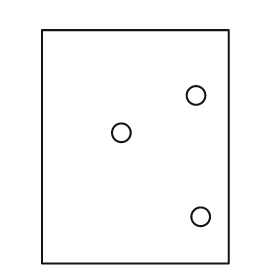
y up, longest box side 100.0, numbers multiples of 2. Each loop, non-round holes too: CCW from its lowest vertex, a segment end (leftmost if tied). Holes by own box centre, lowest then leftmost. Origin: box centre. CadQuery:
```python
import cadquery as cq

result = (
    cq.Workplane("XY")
    .moveTo(-40.0, -50.0)
    .lineTo(40.0, -50.0)
    .lineTo(40.0, 50.0)
    .lineTo(-40.0, 50.0)
    .close()
    .moveTo(28.0, -30.0)
    .circle(4.0)
    .moveTo(-6.0, 6.0)
    .circle(4.0)
    .moveTo(26.0, 22.0)
    .circle(4.0)
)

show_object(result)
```